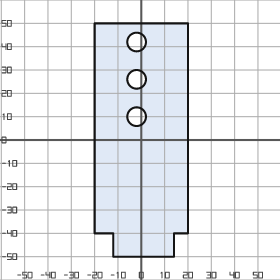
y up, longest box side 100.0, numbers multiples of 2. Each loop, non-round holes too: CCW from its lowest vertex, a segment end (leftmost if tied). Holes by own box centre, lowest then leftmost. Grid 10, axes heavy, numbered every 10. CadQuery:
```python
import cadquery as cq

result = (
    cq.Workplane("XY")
    .moveTo(-12.0, -50.0)
    .lineTo(14.0, -50.0)
    .lineTo(14.0, -40.0)
    .lineTo(20.0, -40.0)
    .lineTo(20.0, 50.0)
    .lineTo(-20.0, 50.0)
    .lineTo(-20.0, -40.0)
    .lineTo(-12.0, -40.0)
    .close()
    .moveTo(-2.0, 10.0)
    .circle(4.0)
    .moveTo(-2.0, 26.0)
    .circle(4.0)
    .moveTo(-2.0, 42.0)
    .circle(4.0)
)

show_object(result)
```